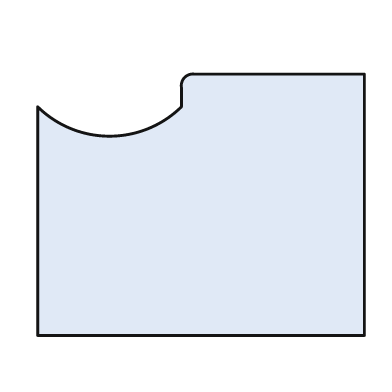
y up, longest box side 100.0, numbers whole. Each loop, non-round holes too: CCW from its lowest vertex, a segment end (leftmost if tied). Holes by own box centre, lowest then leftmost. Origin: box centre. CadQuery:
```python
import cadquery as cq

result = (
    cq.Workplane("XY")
    .moveTo(-50.0, -40.0)
    .lineTo(50.0, -40.0)
    .lineTo(50.0, 40.0)
    .lineTo(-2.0, 40.0)
    .threePointArc((-5.0, 39.0), (-6.0, 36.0))
    .lineTo(-6.0, 30.0)
    .threePointArc((-28.0, 21.0), (-50.0, 30.0))
    .close()
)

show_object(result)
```